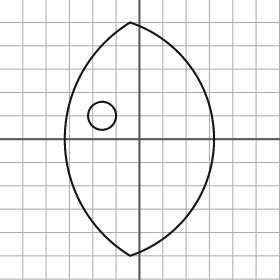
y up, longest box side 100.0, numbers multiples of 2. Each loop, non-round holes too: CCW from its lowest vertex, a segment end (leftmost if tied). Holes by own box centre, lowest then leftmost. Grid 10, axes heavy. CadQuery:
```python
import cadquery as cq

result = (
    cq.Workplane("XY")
    .moveTo(-4.0, -50.0)
    .threePointArc((32.0, 0.0), (-4.0, 50.0))
    .threePointArc((-32.0, 0.0), (-4.0, -50.0))
    .close()
    .moveTo(-16.0, 10.0)
    .circle(6.0)
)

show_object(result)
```